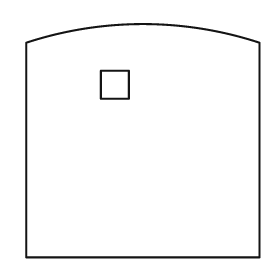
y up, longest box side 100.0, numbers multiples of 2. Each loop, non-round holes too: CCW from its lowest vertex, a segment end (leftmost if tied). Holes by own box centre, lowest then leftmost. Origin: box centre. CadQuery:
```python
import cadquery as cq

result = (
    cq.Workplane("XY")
    .moveTo(-50.0, -50.0)
    .lineTo(50.0, -50.0)
    .lineTo(50.0, 42.0)
    .threePointArc((0.0, 50.0), (-50.0, 42.0))
    .close()
    .moveTo(-18.0, 18.0)
    .lineTo(-6.0, 18.0)
    .lineTo(-6.0, 30.0)
    .lineTo(-18.0, 30.0)
    .close()
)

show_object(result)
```